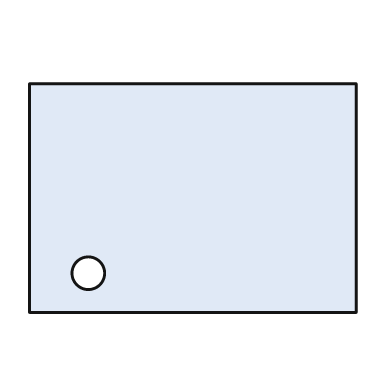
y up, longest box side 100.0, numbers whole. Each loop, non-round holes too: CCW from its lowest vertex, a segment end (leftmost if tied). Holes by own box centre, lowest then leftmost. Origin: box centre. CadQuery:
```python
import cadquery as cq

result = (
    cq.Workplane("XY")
    .moveTo(-50.0, -35.0)
    .lineTo(50.0, -35.0)
    .lineTo(50.0, 35.0)
    .lineTo(-50.0, 35.0)
    .close()
    .moveTo(-32.0, -23.0)
    .circle(5.0)
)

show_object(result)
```